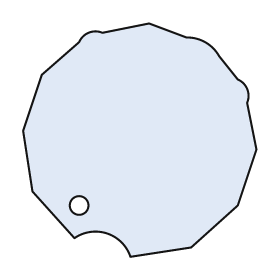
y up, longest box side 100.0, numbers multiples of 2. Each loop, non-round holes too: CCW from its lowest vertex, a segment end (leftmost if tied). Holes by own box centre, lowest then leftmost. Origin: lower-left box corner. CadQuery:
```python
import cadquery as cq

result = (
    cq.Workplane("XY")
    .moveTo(46.0, 0.0)
    .lineTo(72.0, 4.0)
    .lineTo(92.0, 22.0)
    .lineTo(100.0, 46.0)
    .lineTo(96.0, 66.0)
    .threePointArc((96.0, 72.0), (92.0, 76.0))
    .lineTo(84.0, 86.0)
    .threePointArc((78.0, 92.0), (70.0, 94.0))
    .lineTo(54.0, 100.0)
    .lineTo(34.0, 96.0)
    .threePointArc((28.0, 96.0), (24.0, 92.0))
    .lineTo(8.0, 78.0)
    .lineTo(0.0, 54.0)
    .lineTo(4.0, 28.0)
    .lineTo(22.0, 8.0)
    .threePointArc((36.0, 10.0), (46.0, 0.0))
    .close()
    .moveTo(24.0, 22.0)
    .circle(4.0)
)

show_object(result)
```